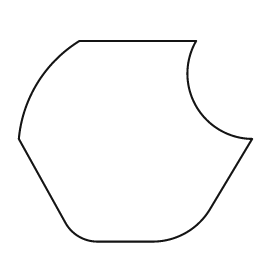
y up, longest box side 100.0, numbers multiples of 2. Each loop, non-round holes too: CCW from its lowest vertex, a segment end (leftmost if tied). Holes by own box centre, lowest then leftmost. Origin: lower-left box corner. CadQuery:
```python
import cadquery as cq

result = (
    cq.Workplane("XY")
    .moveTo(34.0, 0.0)
    .lineTo(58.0, 0.0)
    .threePointArc((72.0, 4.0), (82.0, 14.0))
    .lineTo(100.0, 44.0)
    .threePointArc((76.0, 58.0), (76.0, 86.0))
    .lineTo(26.0, 86.0)
    .threePointArc((8.0, 68.0), (0.0, 44.0))
    .lineTo(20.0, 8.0)
    .threePointArc((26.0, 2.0), (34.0, 0.0))
    .close()
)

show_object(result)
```